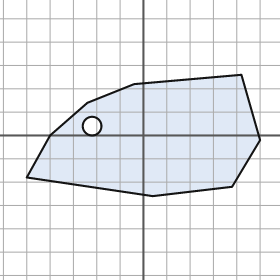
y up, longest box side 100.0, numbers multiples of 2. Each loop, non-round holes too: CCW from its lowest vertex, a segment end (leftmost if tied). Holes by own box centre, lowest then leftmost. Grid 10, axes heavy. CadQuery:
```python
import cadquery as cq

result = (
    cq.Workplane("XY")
    .moveTo(4.0, -26.0)
    .lineTo(38.0, -22.0)
    .lineTo(50.0, -2.0)
    .lineTo(42.0, 26.0)
    .lineTo(-4.0, 22.0)
    .lineTo(-24.0, 14.0)
    .lineTo(-40.0, 0.0)
    .lineTo(-50.0, -18.0)
    .close()
    .moveTo(-22.0, 4.0)
    .circle(4.0)
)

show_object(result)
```